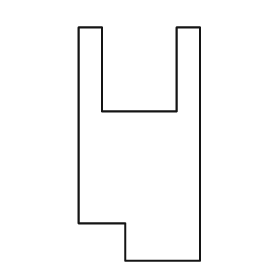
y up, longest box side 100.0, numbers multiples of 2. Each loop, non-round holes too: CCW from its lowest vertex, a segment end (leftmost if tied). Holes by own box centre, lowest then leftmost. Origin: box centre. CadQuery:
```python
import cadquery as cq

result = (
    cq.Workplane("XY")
    .moveTo(-6.0, -50.0)
    .lineTo(26.0, -50.0)
    .lineTo(26.0, 50.0)
    .lineTo(16.0, 50.0)
    .lineTo(16.0, 14.0)
    .lineTo(-16.0, 14.0)
    .lineTo(-16.0, 50.0)
    .lineTo(-26.0, 50.0)
    .lineTo(-26.0, -34.0)
    .lineTo(-6.0, -34.0)
    .close()
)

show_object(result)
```